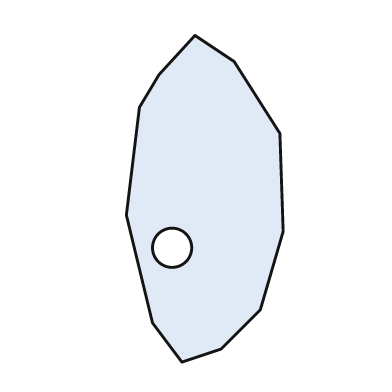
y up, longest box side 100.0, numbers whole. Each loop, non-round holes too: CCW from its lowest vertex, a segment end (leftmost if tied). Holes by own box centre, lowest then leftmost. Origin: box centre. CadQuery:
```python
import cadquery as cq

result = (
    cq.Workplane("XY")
    .moveTo(-7.0, -50.0)
    .lineTo(5.0, -46.0)
    .lineTo(17.0, -34.0)
    .lineTo(24.0, -10.0)
    .lineTo(23.0, 20.0)
    .lineTo(9.0, 42.0)
    .lineTo(-3.0, 50.0)
    .lineTo(-14.0, 38.0)
    .lineTo(-20.0, 28.0)
    .lineTo(-24.0, -5.0)
    .lineTo(-16.0, -38.0)
    .close()
    .moveTo(-10.0, -15.0)
    .circle(6.0)
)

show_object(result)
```